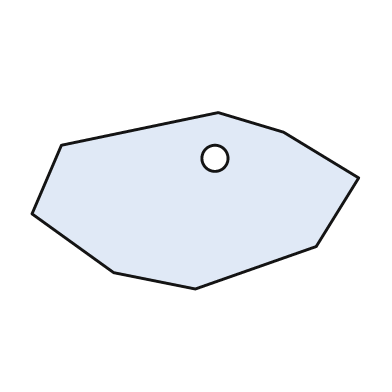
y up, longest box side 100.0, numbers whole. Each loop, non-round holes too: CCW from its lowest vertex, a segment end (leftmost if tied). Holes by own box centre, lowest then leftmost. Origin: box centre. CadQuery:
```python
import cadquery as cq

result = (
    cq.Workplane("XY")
    .moveTo(0.0, -27.0)
    .lineTo(37.0, -14.0)
    .lineTo(50.0, 7.0)
    .lineTo(27.0, 21.0)
    .lineTo(7.0, 27.0)
    .lineTo(-41.0, 17.0)
    .lineTo(-50.0, -4.0)
    .lineTo(-25.0, -22.0)
    .close()
    .moveTo(6.0, 13.0)
    .circle(4.0)
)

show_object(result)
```